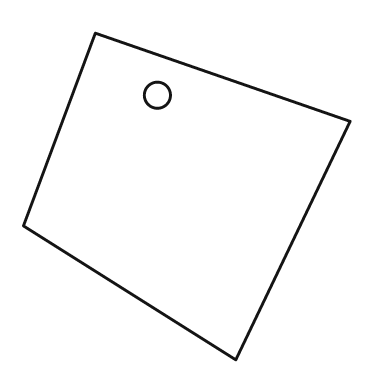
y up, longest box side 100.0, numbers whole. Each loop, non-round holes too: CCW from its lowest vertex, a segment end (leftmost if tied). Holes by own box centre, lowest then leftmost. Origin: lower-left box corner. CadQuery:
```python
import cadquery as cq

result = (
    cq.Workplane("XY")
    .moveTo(65.0, 0.0)
    .lineTo(100.0, 73.0)
    .lineTo(22.0, 100.0)
    .lineTo(0.0, 41.0)
    .close()
    .moveTo(41.0, 81.0)
    .circle(4.0)
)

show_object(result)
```